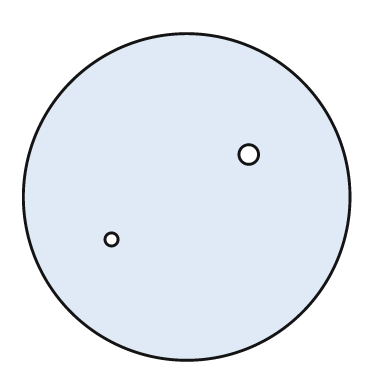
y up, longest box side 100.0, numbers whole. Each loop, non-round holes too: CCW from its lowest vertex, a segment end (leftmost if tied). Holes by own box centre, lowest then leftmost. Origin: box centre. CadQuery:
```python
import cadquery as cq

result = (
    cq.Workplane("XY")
    .moveTo(0.0, 0.0)
    .circle(50.0)
    .moveTo(-23.0, -13.0)
    .circle(2.0)
    .moveTo(19.0, 13.0)
    .circle(3.0)
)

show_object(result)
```